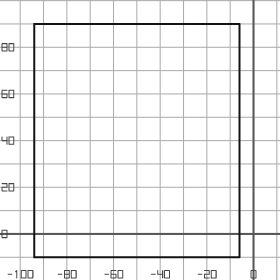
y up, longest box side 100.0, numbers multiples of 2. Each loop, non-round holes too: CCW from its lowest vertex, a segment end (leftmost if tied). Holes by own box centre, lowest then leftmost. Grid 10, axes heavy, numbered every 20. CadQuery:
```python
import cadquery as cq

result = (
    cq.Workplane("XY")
    .moveTo(-94.0, -10.0)
    .lineTo(-6.0, -10.0)
    .lineTo(-6.0, 90.0)
    .lineTo(-94.0, 90.0)
    .close()
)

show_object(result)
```